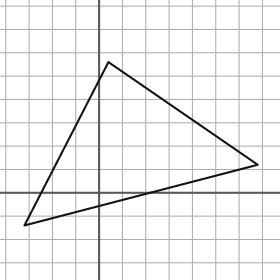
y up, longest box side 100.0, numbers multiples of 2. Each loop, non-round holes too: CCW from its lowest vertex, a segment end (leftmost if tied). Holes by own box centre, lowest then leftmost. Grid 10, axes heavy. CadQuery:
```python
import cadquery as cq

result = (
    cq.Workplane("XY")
    .moveTo(-32.0, -14.0)
    .lineTo(68.0, 12.0)
    .lineTo(4.0, 56.0)
    .close()
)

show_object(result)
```